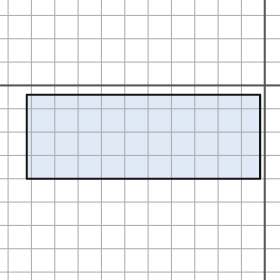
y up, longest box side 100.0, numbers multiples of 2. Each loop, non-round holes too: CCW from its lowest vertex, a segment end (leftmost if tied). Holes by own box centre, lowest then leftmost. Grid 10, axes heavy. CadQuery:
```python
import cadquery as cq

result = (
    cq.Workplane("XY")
    .moveTo(-102.0, -40.0)
    .lineTo(-2.0, -40.0)
    .lineTo(-2.0, -4.0)
    .lineTo(-102.0, -4.0)
    .close()
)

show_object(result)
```